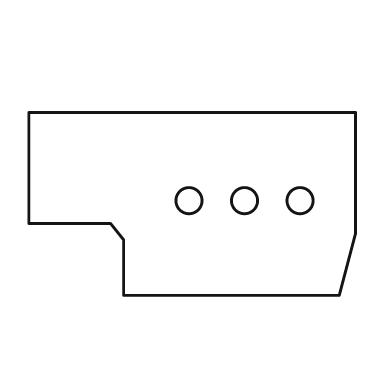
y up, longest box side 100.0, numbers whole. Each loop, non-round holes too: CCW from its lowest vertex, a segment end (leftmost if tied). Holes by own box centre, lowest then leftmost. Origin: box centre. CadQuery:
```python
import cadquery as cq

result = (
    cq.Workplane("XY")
    .moveTo(-21.0, -28.0)
    .lineTo(45.0, -28.0)
    .lineTo(50.0, -9.0)
    .lineTo(50.0, 28.0)
    .lineTo(-50.0, 28.0)
    .lineTo(-50.0, -6.0)
    .lineTo(-25.0, -6.0)
    .lineTo(-21.0, -11.0)
    .close()
    .moveTo(-1.0, 1.0)
    .circle(4.0)
    .moveTo(16.0, 1.0)
    .circle(4.0)
    .moveTo(33.0, 1.0)
    .circle(4.0)
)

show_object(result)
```